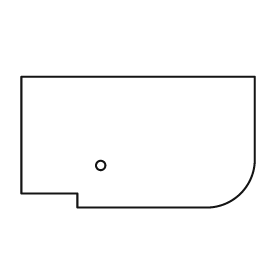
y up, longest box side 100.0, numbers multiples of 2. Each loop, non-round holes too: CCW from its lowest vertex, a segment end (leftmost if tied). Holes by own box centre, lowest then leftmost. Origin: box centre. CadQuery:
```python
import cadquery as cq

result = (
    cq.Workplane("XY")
    .moveTo(-26.0, -28.0)
    .lineTo(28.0, -28.0)
    .threePointArc((44.0, -22.0), (50.0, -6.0))
    .lineTo(50.0, 28.0)
    .lineTo(-50.0, 28.0)
    .lineTo(-50.0, -22.0)
    .lineTo(-26.0, -22.0)
    .close()
    .moveTo(-16.0, -10.0)
    .circle(2.0)
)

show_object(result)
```